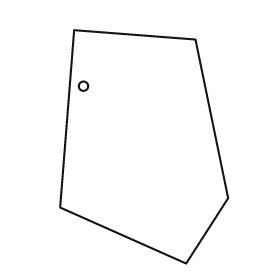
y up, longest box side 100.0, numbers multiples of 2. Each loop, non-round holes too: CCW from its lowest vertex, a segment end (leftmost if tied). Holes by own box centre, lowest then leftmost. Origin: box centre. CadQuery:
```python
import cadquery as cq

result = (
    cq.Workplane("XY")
    .moveTo(18.0, -50.0)
    .lineTo(36.0, -22.0)
    .lineTo(22.0, 46.0)
    .lineTo(-30.0, 50.0)
    .lineTo(-36.0, -26.0)
    .close()
    .moveTo(-26.0, 26.0)
    .circle(2.0)
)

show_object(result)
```